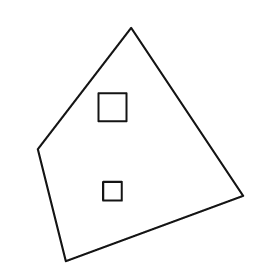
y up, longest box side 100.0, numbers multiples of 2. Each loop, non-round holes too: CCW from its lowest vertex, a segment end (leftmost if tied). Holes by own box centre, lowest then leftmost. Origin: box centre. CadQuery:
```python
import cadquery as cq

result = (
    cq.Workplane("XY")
    .moveTo(-32.0, -50.0)
    .lineTo(44.0, -22.0)
    .lineTo(-4.0, 50.0)
    .lineTo(-44.0, -2.0)
    .close()
    .moveTo(-16.0, -24.0)
    .lineTo(-8.0, -24.0)
    .lineTo(-8.0, -16.0)
    .lineTo(-16.0, -16.0)
    .close()
    .moveTo(-18.0, 10.0)
    .lineTo(-6.0, 10.0)
    .lineTo(-6.0, 22.0)
    .lineTo(-18.0, 22.0)
    .close()
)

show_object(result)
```